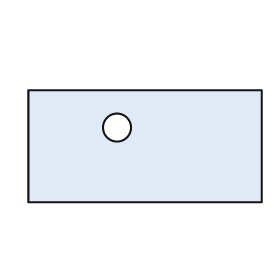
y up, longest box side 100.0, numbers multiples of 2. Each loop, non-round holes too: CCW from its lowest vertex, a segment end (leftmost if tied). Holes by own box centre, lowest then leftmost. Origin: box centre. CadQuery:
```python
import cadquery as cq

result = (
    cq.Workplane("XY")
    .moveTo(-50.0, -24.0)
    .lineTo(50.0, -24.0)
    .lineTo(50.0, 24.0)
    .lineTo(-50.0, 24.0)
    .close()
    .moveTo(-12.0, 8.0)
    .circle(6.0)
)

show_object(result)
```